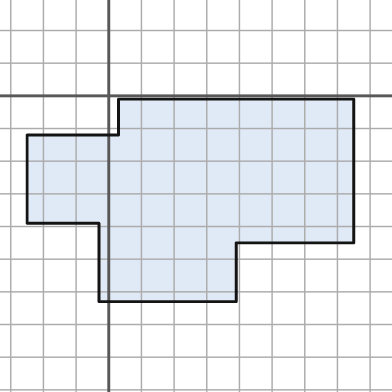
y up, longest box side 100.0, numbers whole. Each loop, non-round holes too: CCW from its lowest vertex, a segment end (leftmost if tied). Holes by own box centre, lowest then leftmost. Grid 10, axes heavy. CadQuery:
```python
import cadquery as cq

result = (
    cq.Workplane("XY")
    .moveTo(-3.0, -63.0)
    .lineTo(39.0, -63.0)
    .lineTo(39.0, -45.0)
    .lineTo(75.0, -45.0)
    .lineTo(75.0, -1.0)
    .lineTo(3.0, -1.0)
    .lineTo(3.0, -12.0)
    .lineTo(-25.0, -12.0)
    .lineTo(-25.0, -39.0)
    .lineTo(-3.0, -39.0)
    .close()
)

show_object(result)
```